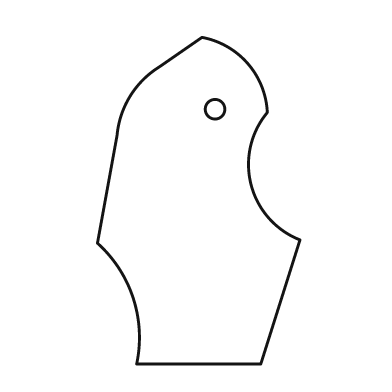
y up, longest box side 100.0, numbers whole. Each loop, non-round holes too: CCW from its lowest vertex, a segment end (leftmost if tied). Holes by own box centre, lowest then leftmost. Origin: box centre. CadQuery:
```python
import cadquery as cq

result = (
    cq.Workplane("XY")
    .moveTo(-19.0, -50.0)
    .lineTo(19.0, -50.0)
    .lineTo(31.0, -12.0)
    .threePointArc((16.0, 5.0), (21.0, 27.0))
    .threePointArc((15.0, 42.0), (1.0, 50.0))
    .lineTo(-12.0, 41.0)
    .threePointArc((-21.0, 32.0), (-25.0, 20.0))
    .lineTo(-31.0, -13.0)
    .threePointArc((-20.0, -30.0), (-19.0, -50.0))
    .close()
    .moveTo(5.0, 28.0)
    .circle(3.0)
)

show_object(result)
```